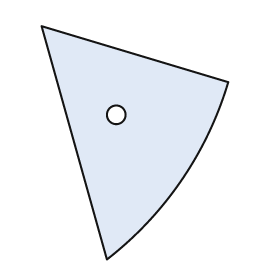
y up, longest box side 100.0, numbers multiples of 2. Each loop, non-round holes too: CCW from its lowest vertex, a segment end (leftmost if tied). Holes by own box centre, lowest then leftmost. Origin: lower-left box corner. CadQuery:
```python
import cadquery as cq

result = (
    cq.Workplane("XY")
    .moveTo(28.0, 0.0)
    .threePointArc((60.0, 34.0), (80.0, 76.0))
    .lineTo(0.0, 100.0)
    .close()
    .moveTo(32.0, 62.0)
    .circle(4.0)
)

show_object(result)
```